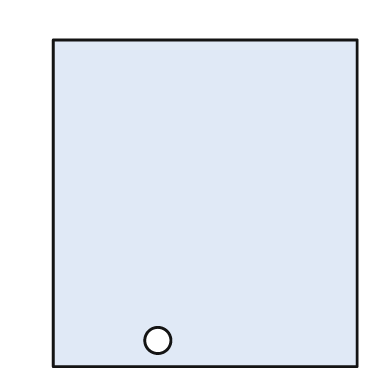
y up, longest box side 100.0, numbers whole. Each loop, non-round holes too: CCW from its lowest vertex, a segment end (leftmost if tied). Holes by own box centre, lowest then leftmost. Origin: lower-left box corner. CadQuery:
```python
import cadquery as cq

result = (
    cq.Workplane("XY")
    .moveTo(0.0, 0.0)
    .lineTo(93.0, 0.0)
    .lineTo(93.0, 100.0)
    .lineTo(0.0, 100.0)
    .close()
    .moveTo(32.0, 8.0)
    .circle(4.0)
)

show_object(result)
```